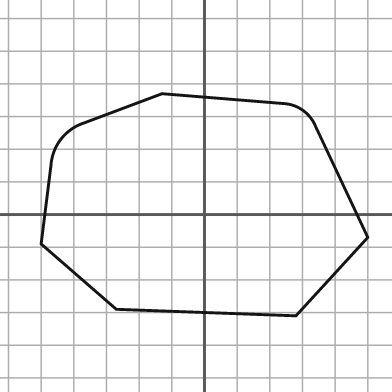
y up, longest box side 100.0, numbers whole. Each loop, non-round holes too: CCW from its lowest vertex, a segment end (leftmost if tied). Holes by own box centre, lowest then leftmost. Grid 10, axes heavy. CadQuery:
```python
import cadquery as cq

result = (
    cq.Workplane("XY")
    .moveTo(28.0, -31.0)
    .lineTo(50.0, -7.0)
    .lineTo(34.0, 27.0)
    .threePointArc((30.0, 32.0), (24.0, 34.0))
    .lineTo(-13.0, 37.0)
    .lineTo(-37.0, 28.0)
    .threePointArc((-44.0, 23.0), (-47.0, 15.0))
    .lineTo(-50.0, -9.0)
    .lineTo(-27.0, -29.0)
    .close()
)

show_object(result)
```